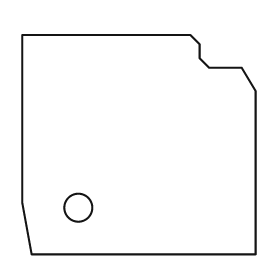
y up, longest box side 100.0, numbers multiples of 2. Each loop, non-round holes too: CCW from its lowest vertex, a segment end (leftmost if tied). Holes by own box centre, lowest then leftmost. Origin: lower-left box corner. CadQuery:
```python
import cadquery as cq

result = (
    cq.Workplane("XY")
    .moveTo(4.0, 0.0)
    .lineTo(100.0, 0.0)
    .lineTo(100.0, 70.0)
    .lineTo(94.0, 80.0)
    .lineTo(80.0, 80.0)
    .lineTo(76.0, 84.0)
    .lineTo(76.0, 90.0)
    .lineTo(72.0, 94.0)
    .lineTo(0.0, 94.0)
    .lineTo(0.0, 22.0)
    .close()
    .moveTo(24.0, 20.0)
    .circle(6.0)
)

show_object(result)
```